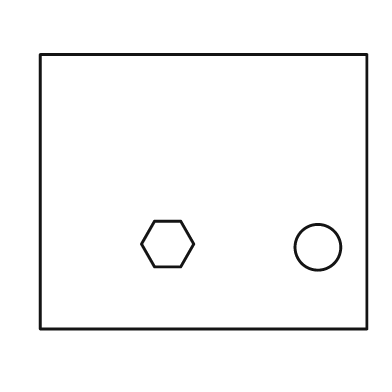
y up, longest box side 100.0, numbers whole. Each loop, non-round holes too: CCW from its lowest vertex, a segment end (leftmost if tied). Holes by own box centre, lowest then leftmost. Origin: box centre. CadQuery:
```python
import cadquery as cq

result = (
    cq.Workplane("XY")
    .moveTo(-50.0, -42.0)
    .lineTo(50.0, -42.0)
    .lineTo(50.0, 42.0)
    .lineTo(-50.0, 42.0)
    .close()
    .moveTo(35.0, -17.0)
    .circle(7.0)
    .moveTo(-15.0, -23.0)
    .lineTo(-7.0, -23.0)
    .lineTo(-3.0, -16.0)
    .lineTo(-7.0, -9.0)
    .lineTo(-15.0, -9.0)
    .lineTo(-19.0, -16.0)
    .close()
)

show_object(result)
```